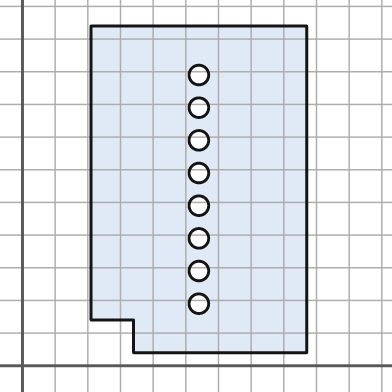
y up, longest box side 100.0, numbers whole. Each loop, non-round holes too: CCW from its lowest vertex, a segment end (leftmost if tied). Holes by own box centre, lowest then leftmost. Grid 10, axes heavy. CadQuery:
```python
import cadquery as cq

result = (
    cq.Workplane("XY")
    .moveTo(34.0, 4.0)
    .lineTo(87.0, 4.0)
    .lineTo(87.0, 104.0)
    .lineTo(21.0, 104.0)
    .lineTo(21.0, 14.0)
    .lineTo(34.0, 14.0)
    .close()
    .moveTo(54.0, 19.0)
    .circle(3.0)
    .moveTo(54.0, 29.0)
    .circle(3.0)
    .moveTo(54.0, 39.0)
    .circle(3.0)
    .moveTo(54.0, 49.0)
    .circle(3.0)
    .moveTo(54.0, 59.0)
    .circle(3.0)
    .moveTo(54.0, 69.0)
    .circle(3.0)
    .moveTo(54.0, 79.0)
    .circle(3.0)
    .moveTo(54.0, 89.0)
    .circle(3.0)
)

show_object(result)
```